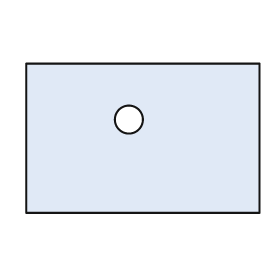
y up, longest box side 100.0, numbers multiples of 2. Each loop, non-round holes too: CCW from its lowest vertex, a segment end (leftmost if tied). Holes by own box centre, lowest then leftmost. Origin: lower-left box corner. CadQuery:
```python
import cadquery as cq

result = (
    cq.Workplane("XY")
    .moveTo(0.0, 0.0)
    .lineTo(100.0, 0.0)
    .lineTo(100.0, 64.0)
    .lineTo(0.0, 64.0)
    .close()
    .moveTo(44.0, 40.0)
    .circle(6.0)
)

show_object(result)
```